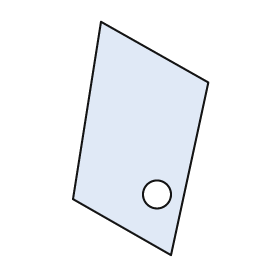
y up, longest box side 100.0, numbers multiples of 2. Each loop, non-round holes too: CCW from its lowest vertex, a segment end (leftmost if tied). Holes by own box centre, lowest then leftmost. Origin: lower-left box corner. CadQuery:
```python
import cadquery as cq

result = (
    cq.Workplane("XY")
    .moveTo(42.0, 0.0)
    .lineTo(58.0, 74.0)
    .lineTo(12.0, 100.0)
    .lineTo(0.0, 24.0)
    .close()
    .moveTo(36.0, 26.0)
    .circle(6.0)
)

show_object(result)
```